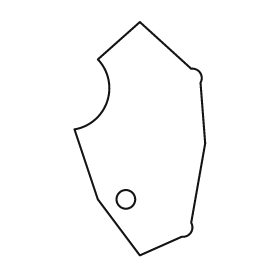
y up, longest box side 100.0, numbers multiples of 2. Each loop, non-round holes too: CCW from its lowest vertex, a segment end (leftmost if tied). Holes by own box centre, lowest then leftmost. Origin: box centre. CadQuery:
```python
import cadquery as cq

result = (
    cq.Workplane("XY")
    .moveTo(0.0, -50.0)
    .lineTo(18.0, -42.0)
    .threePointArc((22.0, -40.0), (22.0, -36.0))
    .lineTo(28.0, -2.0)
    .lineTo(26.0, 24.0)
    .threePointArc((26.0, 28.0), (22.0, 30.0))
    .lineTo(0.0, 50.0)
    .lineTo(-18.0, 34.0)
    .threePointArc((-14.0, 16.0), (-28.0, 4.0))
    .lineTo(-18.0, -26.0)
    .close()
    .moveTo(-6.0, -26.0)
    .circle(4.0)
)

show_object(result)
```